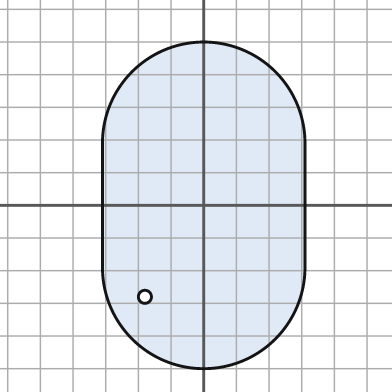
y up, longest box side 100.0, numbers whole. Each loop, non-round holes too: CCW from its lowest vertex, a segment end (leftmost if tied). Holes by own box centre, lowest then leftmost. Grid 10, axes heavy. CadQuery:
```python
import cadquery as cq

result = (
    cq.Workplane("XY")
    .moveTo(-31.0, -19.0)
    .threePointArc((0.0, -50.0), (31.0, -19.0))
    .lineTo(31.0, 19.0)
    .threePointArc((0.0, 50.0), (-31.0, 19.0))
    .close()
    .moveTo(-18.0, -28.0)
    .circle(2.0)
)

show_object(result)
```